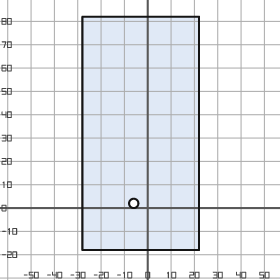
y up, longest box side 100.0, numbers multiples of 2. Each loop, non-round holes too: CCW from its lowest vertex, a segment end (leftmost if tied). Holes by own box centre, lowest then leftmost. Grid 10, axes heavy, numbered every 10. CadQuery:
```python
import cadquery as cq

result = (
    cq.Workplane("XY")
    .moveTo(-28.0, -18.0)
    .lineTo(22.0, -18.0)
    .lineTo(22.0, 82.0)
    .lineTo(-28.0, 82.0)
    .close()
    .moveTo(-6.0, 2.0)
    .circle(2.0)
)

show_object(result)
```